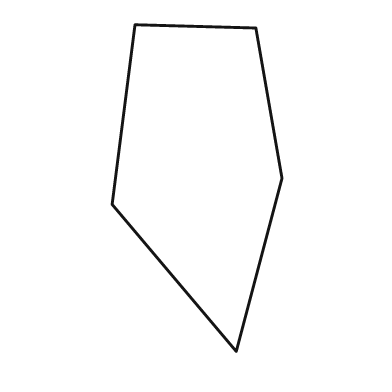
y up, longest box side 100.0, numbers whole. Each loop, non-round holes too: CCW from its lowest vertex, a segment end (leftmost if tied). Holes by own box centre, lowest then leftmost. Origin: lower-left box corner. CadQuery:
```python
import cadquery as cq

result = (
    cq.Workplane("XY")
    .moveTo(38.0, 0.0)
    .lineTo(52.0, 53.0)
    .lineTo(44.0, 99.0)
    .lineTo(7.0, 100.0)
    .lineTo(0.0, 45.0)
    .close()
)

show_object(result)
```